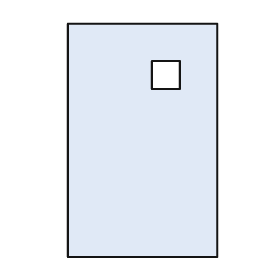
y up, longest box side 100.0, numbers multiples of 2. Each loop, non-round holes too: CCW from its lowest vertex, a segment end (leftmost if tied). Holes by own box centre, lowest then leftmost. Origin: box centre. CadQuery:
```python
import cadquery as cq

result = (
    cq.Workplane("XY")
    .moveTo(-32.0, -50.0)
    .lineTo(32.0, -50.0)
    .lineTo(32.0, 50.0)
    .lineTo(-32.0, 50.0)
    .close()
    .moveTo(4.0, 22.0)
    .lineTo(16.0, 22.0)
    .lineTo(16.0, 34.0)
    .lineTo(4.0, 34.0)
    .close()
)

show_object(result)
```